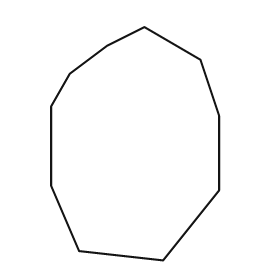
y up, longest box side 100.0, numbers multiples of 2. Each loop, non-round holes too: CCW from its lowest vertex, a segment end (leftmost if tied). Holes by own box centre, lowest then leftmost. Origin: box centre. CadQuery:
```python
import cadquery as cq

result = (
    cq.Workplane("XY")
    .moveTo(12.0, -50.0)
    .lineTo(36.0, -20.0)
    .lineTo(36.0, 12.0)
    .lineTo(28.0, 36.0)
    .lineTo(4.0, 50.0)
    .lineTo(-12.0, 42.0)
    .lineTo(-28.0, 30.0)
    .lineTo(-36.0, 16.0)
    .lineTo(-36.0, -18.0)
    .lineTo(-24.0, -46.0)
    .close()
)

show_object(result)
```